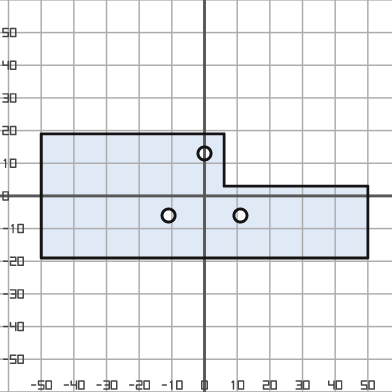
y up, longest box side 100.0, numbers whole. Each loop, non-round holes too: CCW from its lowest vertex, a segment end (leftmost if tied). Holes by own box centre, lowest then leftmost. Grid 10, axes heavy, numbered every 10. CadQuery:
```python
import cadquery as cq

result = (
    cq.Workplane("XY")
    .moveTo(-50.0, -19.0)
    .lineTo(50.0, -19.0)
    .lineTo(50.0, 3.0)
    .lineTo(6.0, 3.0)
    .lineTo(6.0, 19.0)
    .lineTo(-50.0, 19.0)
    .close()
    .moveTo(-11.0, -6.0)
    .circle(2.0)
    .moveTo(11.0, -6.0)
    .circle(2.0)
    .moveTo(0.0, 13.0)
    .circle(2.0)
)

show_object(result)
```